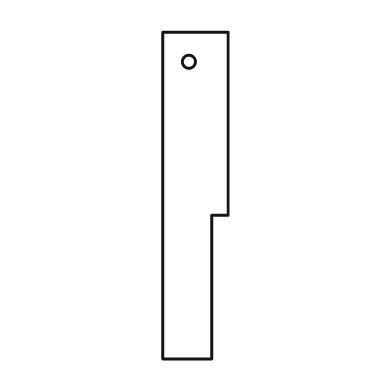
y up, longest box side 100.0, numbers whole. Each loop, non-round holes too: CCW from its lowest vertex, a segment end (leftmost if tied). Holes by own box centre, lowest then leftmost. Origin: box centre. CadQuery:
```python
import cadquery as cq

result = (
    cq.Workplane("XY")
    .moveTo(-10.0, -50.0)
    .lineTo(5.0, -50.0)
    .lineTo(5.0, -6.0)
    .lineTo(10.0, -6.0)
    .lineTo(10.0, 50.0)
    .lineTo(-10.0, 50.0)
    .close()
    .moveTo(-2.0, 41.0)
    .circle(2.0)
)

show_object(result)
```